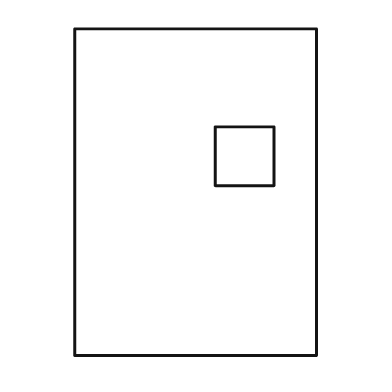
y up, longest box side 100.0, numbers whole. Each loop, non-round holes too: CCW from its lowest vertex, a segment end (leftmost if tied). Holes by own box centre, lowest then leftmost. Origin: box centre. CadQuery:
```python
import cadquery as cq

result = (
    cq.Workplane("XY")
    .moveTo(-37.0, -50.0)
    .lineTo(37.0, -50.0)
    .lineTo(37.0, 50.0)
    .lineTo(-37.0, 50.0)
    .close()
    .moveTo(6.0, 2.0)
    .lineTo(24.0, 2.0)
    .lineTo(24.0, 20.0)
    .lineTo(6.0, 20.0)
    .close()
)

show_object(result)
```